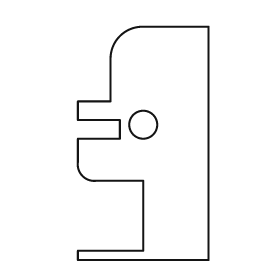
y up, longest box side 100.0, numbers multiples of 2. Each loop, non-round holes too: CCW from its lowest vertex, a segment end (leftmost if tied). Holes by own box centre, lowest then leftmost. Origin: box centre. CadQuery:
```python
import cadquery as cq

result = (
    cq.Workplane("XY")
    .moveTo(-28.0, -50.0)
    .lineTo(28.0, -50.0)
    .lineTo(28.0, 50.0)
    .lineTo(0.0, 50.0)
    .threePointArc((-10.0, 46.0), (-14.0, 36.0))
    .lineTo(-14.0, 18.0)
    .lineTo(-28.0, 18.0)
    .lineTo(-28.0, 10.0)
    .lineTo(-10.0, 10.0)
    .lineTo(-10.0, 2.0)
    .lineTo(-28.0, 2.0)
    .lineTo(-28.0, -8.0)
    .threePointArc((-26.0, -14.0), (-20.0, -16.0))
    .lineTo(0.0, -16.0)
    .lineTo(0.0, -46.0)
    .lineTo(-28.0, -46.0)
    .close()
    .moveTo(0.0, 8.0)
    .circle(6.0)
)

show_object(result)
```